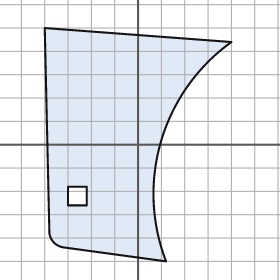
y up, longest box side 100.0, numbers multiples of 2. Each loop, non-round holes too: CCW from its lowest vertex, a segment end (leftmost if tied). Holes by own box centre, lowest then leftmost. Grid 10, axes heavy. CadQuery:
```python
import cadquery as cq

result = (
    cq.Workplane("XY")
    .moveTo(12.0, -50.0)
    .threePointArc((10.0, 2.0), (40.0, 44.0))
    .lineTo(-40.0, 50.0)
    .lineTo(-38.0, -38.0)
    .threePointArc((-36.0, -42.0), (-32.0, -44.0))
    .close()
    .moveTo(-30.0, -26.0)
    .lineTo(-22.0, -26.0)
    .lineTo(-22.0, -18.0)
    .lineTo(-30.0, -18.0)
    .close()
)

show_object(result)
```